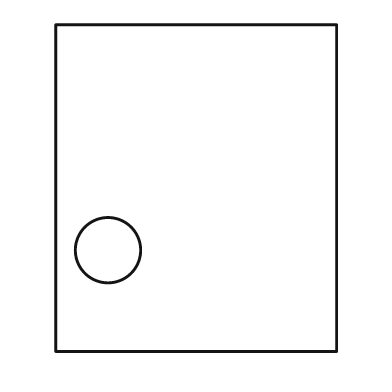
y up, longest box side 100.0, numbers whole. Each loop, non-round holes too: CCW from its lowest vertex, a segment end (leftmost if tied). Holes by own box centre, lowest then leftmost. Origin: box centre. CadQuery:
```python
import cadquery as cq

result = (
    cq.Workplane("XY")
    .moveTo(-43.0, -50.0)
    .lineTo(43.0, -50.0)
    .lineTo(43.0, 50.0)
    .lineTo(-43.0, 50.0)
    .close()
    .moveTo(-27.0, -19.0)
    .circle(10.0)
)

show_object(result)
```